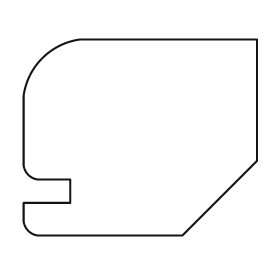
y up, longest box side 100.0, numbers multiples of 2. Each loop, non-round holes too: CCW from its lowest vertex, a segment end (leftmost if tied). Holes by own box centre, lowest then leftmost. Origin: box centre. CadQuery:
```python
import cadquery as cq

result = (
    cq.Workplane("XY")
    .moveTo(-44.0, -42.0)
    .lineTo(18.0, -42.0)
    .lineTo(50.0, -10.0)
    .lineTo(50.0, 42.0)
    .lineTo(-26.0, 42.0)
    .threePointArc((-42.0, 34.0), (-50.0, 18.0))
    .lineTo(-50.0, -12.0)
    .threePointArc((-48.0, -16.0), (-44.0, -18.0))
    .lineTo(-30.0, -18.0)
    .lineTo(-30.0, -28.0)
    .lineTo(-50.0, -28.0)
    .lineTo(-50.0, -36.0)
    .threePointArc((-48.0, -40.0), (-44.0, -42.0))
    .close()
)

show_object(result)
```